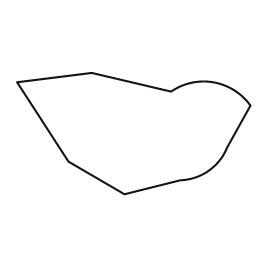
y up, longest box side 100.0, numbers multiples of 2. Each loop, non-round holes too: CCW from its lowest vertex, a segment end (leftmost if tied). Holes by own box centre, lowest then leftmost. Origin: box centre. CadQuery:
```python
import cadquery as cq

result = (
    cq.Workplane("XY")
    .moveTo(-4.0, -26.0)
    .lineTo(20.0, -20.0)
    .threePointArc((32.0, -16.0), (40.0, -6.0))
    .lineTo(50.0, 12.0)
    .threePointArc((34.0, 22.0), (16.0, 18.0))
    .lineTo(-18.0, 26.0)
    .lineTo(-50.0, 22.0)
    .lineTo(-28.0, -12.0)
    .close()
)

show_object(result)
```